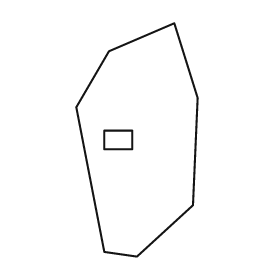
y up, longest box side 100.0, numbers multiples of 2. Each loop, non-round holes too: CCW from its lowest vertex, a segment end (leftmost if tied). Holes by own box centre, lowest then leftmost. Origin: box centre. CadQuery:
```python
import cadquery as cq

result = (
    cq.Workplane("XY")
    .moveTo(0.0, -50.0)
    .lineTo(24.0, -28.0)
    .lineTo(26.0, 18.0)
    .lineTo(16.0, 50.0)
    .lineTo(-12.0, 38.0)
    .lineTo(-26.0, 14.0)
    .lineTo(-14.0, -48.0)
    .close()
    .moveTo(-14.0, -4.0)
    .lineTo(-2.0, -4.0)
    .lineTo(-2.0, 4.0)
    .lineTo(-14.0, 4.0)
    .close()
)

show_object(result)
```